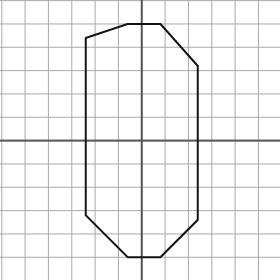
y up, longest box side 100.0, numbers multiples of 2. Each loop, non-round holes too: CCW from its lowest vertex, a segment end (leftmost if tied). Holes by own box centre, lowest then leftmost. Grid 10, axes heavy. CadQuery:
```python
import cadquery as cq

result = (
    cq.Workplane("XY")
    .moveTo(-6.0, -50.0)
    .lineTo(8.0, -50.0)
    .lineTo(24.0, -34.0)
    .lineTo(24.0, 32.0)
    .lineTo(8.0, 50.0)
    .lineTo(-6.0, 50.0)
    .lineTo(-24.0, 44.0)
    .lineTo(-24.0, -32.0)
    .close()
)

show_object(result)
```